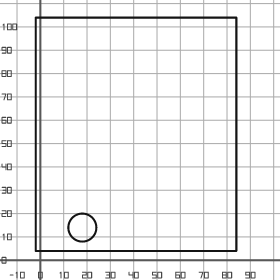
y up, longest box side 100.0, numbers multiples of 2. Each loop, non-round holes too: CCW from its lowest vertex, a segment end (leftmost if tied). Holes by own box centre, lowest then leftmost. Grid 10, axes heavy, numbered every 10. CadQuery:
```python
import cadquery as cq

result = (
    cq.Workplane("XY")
    .moveTo(-2.0, 4.0)
    .lineTo(84.0, 4.0)
    .lineTo(84.0, 104.0)
    .lineTo(-2.0, 104.0)
    .close()
    .moveTo(18.0, 14.0)
    .circle(6.0)
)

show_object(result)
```